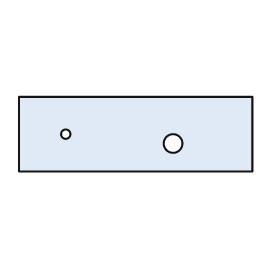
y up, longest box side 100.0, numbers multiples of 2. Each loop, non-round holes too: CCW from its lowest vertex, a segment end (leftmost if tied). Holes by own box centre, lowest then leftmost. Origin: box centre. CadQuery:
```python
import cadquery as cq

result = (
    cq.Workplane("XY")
    .moveTo(-50.0, -16.0)
    .lineTo(50.0, -16.0)
    .lineTo(50.0, 16.0)
    .lineTo(-50.0, 16.0)
    .close()
    .moveTo(16.0, -4.0)
    .circle(4.0)
    .moveTo(-30.0, 0.0)
    .circle(2.0)
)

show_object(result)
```